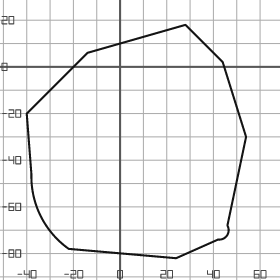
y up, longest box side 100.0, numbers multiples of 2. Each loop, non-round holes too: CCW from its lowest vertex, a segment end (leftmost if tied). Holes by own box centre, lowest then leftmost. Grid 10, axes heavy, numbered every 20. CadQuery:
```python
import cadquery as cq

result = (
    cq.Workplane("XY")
    .moveTo(24.0, -82.0)
    .lineTo(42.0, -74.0)
    .threePointArc((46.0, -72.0), (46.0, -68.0))
    .lineTo(54.0, -30.0)
    .lineTo(44.0, 2.0)
    .lineTo(28.0, 18.0)
    .lineTo(-14.0, 6.0)
    .lineTo(-40.0, -20.0)
    .lineTo(-38.0, -46.0)
    .threePointArc((-34.0, -64.0), (-22.0, -78.0))
    .close()
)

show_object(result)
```